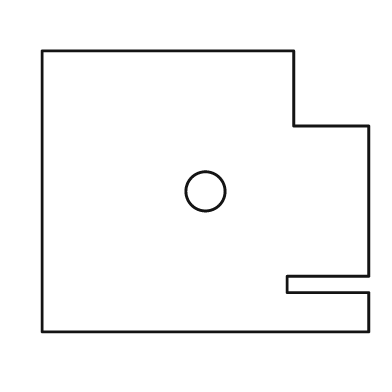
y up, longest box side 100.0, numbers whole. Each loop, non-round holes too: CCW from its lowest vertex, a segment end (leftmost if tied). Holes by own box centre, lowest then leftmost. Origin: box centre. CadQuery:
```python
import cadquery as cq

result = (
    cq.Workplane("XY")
    .moveTo(-50.0, -43.0)
    .lineTo(50.0, -43.0)
    .lineTo(50.0, -31.0)
    .lineTo(25.0, -31.0)
    .lineTo(25.0, -26.0)
    .lineTo(50.0, -26.0)
    .lineTo(50.0, 20.0)
    .lineTo(27.0, 20.0)
    .lineTo(27.0, 43.0)
    .lineTo(-50.0, 43.0)
    .close()
    .moveTo(0.0, 0.0)
    .circle(6.0)
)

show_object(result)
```